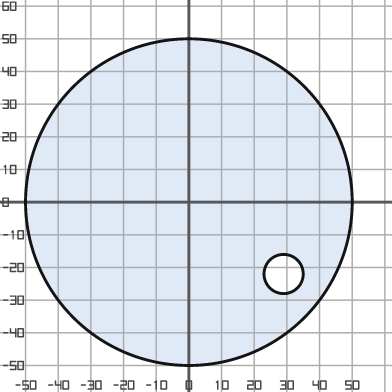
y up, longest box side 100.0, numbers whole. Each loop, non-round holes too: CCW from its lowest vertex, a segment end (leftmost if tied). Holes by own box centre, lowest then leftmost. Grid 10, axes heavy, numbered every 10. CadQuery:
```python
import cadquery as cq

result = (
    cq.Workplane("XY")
    .moveTo(0.0, 0.0)
    .circle(50.0)
    .moveTo(29.0, -22.0)
    .circle(6.0)
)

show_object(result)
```